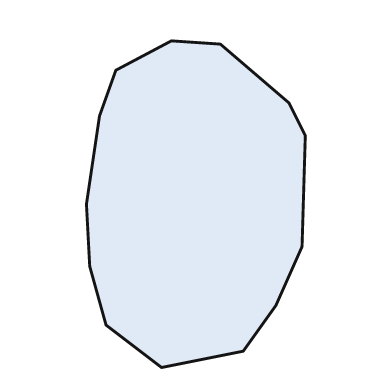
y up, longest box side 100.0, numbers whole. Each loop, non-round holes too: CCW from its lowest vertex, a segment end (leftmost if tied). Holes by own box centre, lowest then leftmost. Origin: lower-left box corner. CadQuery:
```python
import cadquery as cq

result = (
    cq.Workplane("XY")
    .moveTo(23.0, 0.0)
    .lineTo(48.0, 5.0)
    .lineTo(58.0, 19.0)
    .lineTo(66.0, 37.0)
    .lineTo(67.0, 71.0)
    .lineTo(62.0, 81.0)
    .lineTo(41.0, 99.0)
    .lineTo(26.0, 100.0)
    .lineTo(9.0, 91.0)
    .lineTo(4.0, 77.0)
    .lineTo(0.0, 50.0)
    .lineTo(1.0, 31.0)
    .lineTo(6.0, 13.0)
    .close()
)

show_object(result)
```